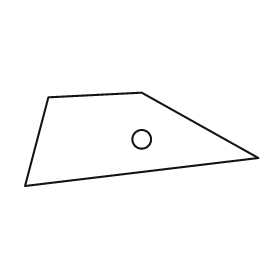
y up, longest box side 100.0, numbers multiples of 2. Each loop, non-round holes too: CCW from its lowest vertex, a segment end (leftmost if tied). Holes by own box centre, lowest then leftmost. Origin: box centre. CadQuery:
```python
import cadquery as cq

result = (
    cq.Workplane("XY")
    .moveTo(-50.0, -20.0)
    .lineTo(50.0, -8.0)
    .lineTo(0.0, 20.0)
    .lineTo(-40.0, 18.0)
    .close()
    .moveTo(0.0, 0.0)
    .circle(4.0)
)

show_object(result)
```